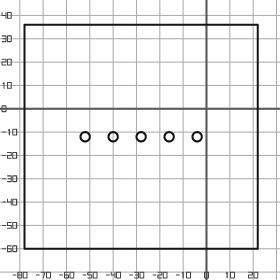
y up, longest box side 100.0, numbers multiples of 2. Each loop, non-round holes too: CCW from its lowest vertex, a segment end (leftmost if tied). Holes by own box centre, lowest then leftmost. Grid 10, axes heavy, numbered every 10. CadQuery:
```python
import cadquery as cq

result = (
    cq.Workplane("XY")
    .moveTo(-78.0, -60.0)
    .lineTo(22.0, -60.0)
    .lineTo(22.0, 36.0)
    .lineTo(-78.0, 36.0)
    .close()
    .moveTo(-52.0, -12.0)
    .circle(2.0)
    .moveTo(-40.0, -12.0)
    .circle(2.0)
    .moveTo(-28.0, -12.0)
    .circle(2.0)
    .moveTo(-16.0, -12.0)
    .circle(2.0)
    .moveTo(-4.0, -12.0)
    .circle(2.0)
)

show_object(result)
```